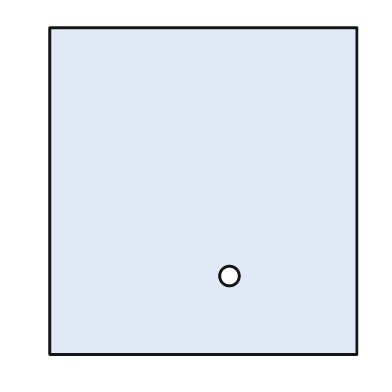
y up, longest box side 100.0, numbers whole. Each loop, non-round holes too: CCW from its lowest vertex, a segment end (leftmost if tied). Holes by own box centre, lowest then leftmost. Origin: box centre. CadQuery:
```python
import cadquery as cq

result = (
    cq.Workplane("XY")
    .moveTo(-47.0, -50.0)
    .lineTo(47.0, -50.0)
    .lineTo(47.0, 50.0)
    .lineTo(-47.0, 50.0)
    .close()
    .moveTo(8.0, -26.0)
    .circle(3.0)
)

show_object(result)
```